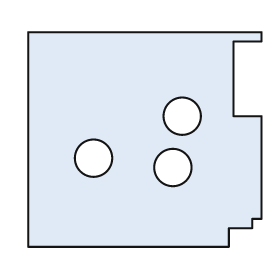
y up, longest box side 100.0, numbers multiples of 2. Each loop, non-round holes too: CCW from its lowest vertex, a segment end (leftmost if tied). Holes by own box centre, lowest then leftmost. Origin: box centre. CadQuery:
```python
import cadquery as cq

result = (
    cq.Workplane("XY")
    .moveTo(-50.0, -46.0)
    .lineTo(36.0, -46.0)
    .lineTo(36.0, -38.0)
    .lineTo(46.0, -38.0)
    .lineTo(46.0, -34.0)
    .lineTo(50.0, -34.0)
    .lineTo(50.0, 10.0)
    .lineTo(38.0, 10.0)
    .lineTo(38.0, 42.0)
    .lineTo(50.0, 42.0)
    .lineTo(50.0, 46.0)
    .lineTo(-50.0, 46.0)
    .close()
    .moveTo(12.0, -12.0)
    .circle(8.0)
    .moveTo(-22.0, -8.0)
    .circle(8.0)
    .moveTo(16.0, 10.0)
    .circle(8.0)
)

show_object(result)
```